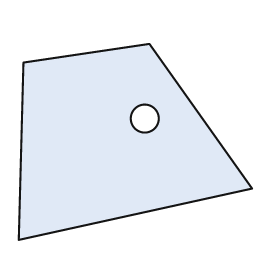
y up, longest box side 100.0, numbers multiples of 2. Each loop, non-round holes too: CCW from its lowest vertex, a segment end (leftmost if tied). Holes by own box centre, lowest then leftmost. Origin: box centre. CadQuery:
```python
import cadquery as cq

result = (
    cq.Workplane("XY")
    .moveTo(-50.0, -42.0)
    .lineTo(50.0, -20.0)
    .lineTo(6.0, 42.0)
    .lineTo(-48.0, 34.0)
    .close()
    .moveTo(4.0, 10.0)
    .circle(6.0)
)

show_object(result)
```